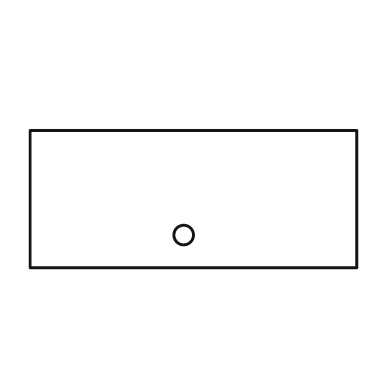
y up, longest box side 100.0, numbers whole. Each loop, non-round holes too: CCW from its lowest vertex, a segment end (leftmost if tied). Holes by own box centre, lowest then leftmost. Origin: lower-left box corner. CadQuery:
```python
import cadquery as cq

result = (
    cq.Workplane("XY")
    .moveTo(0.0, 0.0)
    .lineTo(100.0, 0.0)
    .lineTo(100.0, 42.0)
    .lineTo(0.0, 42.0)
    .close()
    .moveTo(47.0, 10.0)
    .circle(3.0)
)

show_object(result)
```